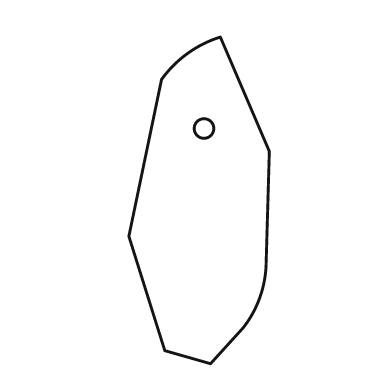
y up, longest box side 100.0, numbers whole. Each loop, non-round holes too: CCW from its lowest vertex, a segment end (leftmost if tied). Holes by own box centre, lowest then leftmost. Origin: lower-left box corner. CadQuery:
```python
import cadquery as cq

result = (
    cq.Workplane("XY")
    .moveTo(25.0, 0.0)
    .lineTo(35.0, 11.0)
    .threePointArc((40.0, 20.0), (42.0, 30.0))
    .lineTo(43.0, 65.0)
    .lineTo(28.0, 100.0)
    .threePointArc((18.0, 95.0), (10.0, 87.0))
    .lineTo(0.0, 39.0)
    .lineTo(11.0, 4.0)
    .close()
    .moveTo(23.0, 72.0)
    .circle(3.0)
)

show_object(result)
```